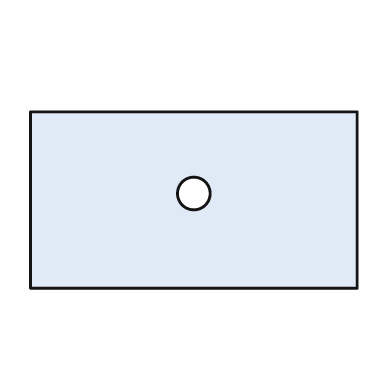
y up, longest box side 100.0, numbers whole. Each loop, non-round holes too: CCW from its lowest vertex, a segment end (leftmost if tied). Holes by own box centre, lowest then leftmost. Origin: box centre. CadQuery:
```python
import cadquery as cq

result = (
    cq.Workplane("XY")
    .moveTo(-50.0, -27.0)
    .lineTo(50.0, -27.0)
    .lineTo(50.0, 27.0)
    .lineTo(-50.0, 27.0)
    .close()
    .moveTo(0.0, 2.0)
    .circle(5.0)
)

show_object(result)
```